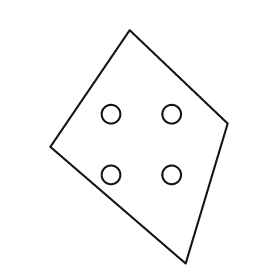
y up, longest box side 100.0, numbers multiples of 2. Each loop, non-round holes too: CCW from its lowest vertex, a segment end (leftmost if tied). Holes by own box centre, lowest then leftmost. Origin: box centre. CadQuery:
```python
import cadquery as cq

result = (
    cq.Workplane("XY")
    .moveTo(20.0, -50.0)
    .lineTo(38.0, 10.0)
    .lineTo(-4.0, 50.0)
    .lineTo(-38.0, 0.0)
    .close()
    .moveTo(-12.0, -12.0)
    .circle(4.0)
    .moveTo(14.0, -12.0)
    .circle(4.0)
    .moveTo(-12.0, 14.0)
    .circle(4.0)
    .moveTo(14.0, 14.0)
    .circle(4.0)
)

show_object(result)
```